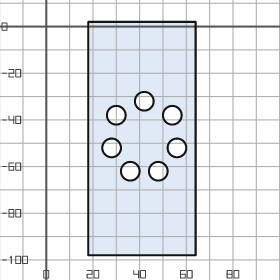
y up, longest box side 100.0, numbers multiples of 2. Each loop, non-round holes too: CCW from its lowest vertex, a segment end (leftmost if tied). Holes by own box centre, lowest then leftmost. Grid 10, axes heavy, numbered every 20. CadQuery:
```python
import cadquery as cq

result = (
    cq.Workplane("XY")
    .moveTo(18.0, -98.0)
    .lineTo(64.0, -98.0)
    .lineTo(64.0, 2.0)
    .lineTo(18.0, 2.0)
    .close()
    .moveTo(36.0, -62.0)
    .circle(4.0)
    .moveTo(48.0, -62.0)
    .circle(4.0)
    .moveTo(28.0, -52.0)
    .circle(4.0)
    .moveTo(56.0, -52.0)
    .circle(4.0)
    .moveTo(30.0, -38.0)
    .circle(4.0)
    .moveTo(54.0, -38.0)
    .circle(4.0)
    .moveTo(42.0, -32.0)
    .circle(4.0)
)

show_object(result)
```